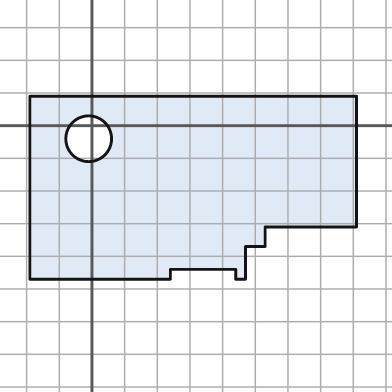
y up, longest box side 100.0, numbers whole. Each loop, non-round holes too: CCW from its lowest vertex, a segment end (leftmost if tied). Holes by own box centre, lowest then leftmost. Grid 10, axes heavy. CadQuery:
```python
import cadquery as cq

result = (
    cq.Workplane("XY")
    .moveTo(-19.0, -47.0)
    .lineTo(24.0, -47.0)
    .lineTo(24.0, -44.0)
    .lineTo(44.0, -44.0)
    .lineTo(44.0, -47.0)
    .lineTo(47.0, -47.0)
    .lineTo(47.0, -37.0)
    .lineTo(53.0, -37.0)
    .lineTo(53.0, -31.0)
    .lineTo(81.0, -31.0)
    .lineTo(81.0, 9.0)
    .lineTo(-19.0, 9.0)
    .close()
    .moveTo(-1.0, -4.0)
    .circle(7.0)
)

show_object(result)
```